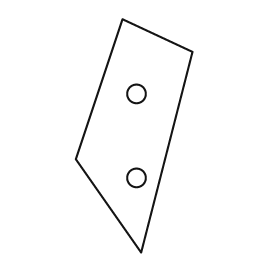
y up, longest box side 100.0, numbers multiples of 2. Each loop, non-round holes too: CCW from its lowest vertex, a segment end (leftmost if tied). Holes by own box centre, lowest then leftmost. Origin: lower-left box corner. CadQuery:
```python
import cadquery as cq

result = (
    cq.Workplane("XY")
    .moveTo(28.0, 0.0)
    .lineTo(50.0, 86.0)
    .lineTo(20.0, 100.0)
    .lineTo(0.0, 40.0)
    .close()
    .moveTo(26.0, 32.0)
    .circle(4.0)
    .moveTo(26.0, 68.0)
    .circle(4.0)
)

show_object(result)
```